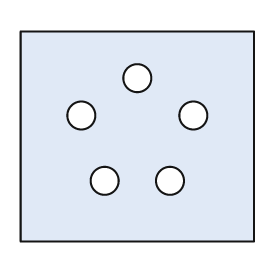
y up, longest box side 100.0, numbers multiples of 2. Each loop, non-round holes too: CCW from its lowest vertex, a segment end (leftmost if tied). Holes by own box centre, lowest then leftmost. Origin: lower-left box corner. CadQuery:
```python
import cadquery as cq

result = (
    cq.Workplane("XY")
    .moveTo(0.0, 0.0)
    .lineTo(100.0, 0.0)
    .lineTo(100.0, 90.0)
    .lineTo(0.0, 90.0)
    .close()
    .moveTo(36.0, 26.0)
    .circle(6.0)
    .moveTo(64.0, 26.0)
    .circle(6.0)
    .moveTo(26.0, 54.0)
    .circle(6.0)
    .moveTo(74.0, 54.0)
    .circle(6.0)
    .moveTo(50.0, 70.0)
    .circle(6.0)
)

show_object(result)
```